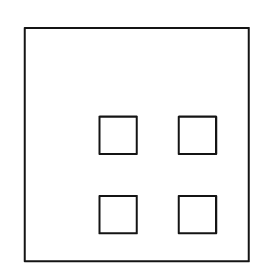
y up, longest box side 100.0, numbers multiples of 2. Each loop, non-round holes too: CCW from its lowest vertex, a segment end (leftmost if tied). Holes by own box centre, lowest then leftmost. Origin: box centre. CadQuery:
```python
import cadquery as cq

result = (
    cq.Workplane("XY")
    .moveTo(-48.0, -50.0)
    .lineTo(48.0, -50.0)
    .lineTo(48.0, 50.0)
    .lineTo(-48.0, 50.0)
    .close()
    .moveTo(-16.0, -38.0)
    .lineTo(0.0, -38.0)
    .lineTo(0.0, -22.0)
    .lineTo(-16.0, -22.0)
    .close()
    .moveTo(18.0, -38.0)
    .lineTo(34.0, -38.0)
    .lineTo(34.0, -22.0)
    .lineTo(18.0, -22.0)
    .close()
    .moveTo(-16.0, -4.0)
    .lineTo(0.0, -4.0)
    .lineTo(0.0, 12.0)
    .lineTo(-16.0, 12.0)
    .close()
    .moveTo(18.0, -4.0)
    .lineTo(34.0, -4.0)
    .lineTo(34.0, 12.0)
    .lineTo(18.0, 12.0)
    .close()
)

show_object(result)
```